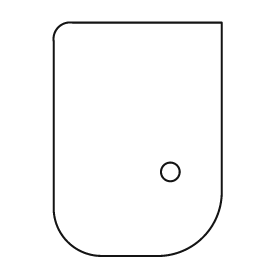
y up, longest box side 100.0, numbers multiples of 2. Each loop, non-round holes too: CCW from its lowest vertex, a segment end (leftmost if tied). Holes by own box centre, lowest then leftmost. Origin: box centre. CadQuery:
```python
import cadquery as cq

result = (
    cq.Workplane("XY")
    .moveTo(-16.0, -50.0)
    .lineTo(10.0, -50.0)
    .threePointArc((28.0, -42.0), (36.0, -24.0))
    .lineTo(36.0, 50.0)
    .lineTo(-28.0, 50.0)
    .threePointArc((-34.0, 48.0), (-36.0, 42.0))
    .lineTo(-36.0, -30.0)
    .threePointArc((-30.0, -44.0), (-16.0, -50.0))
    .close()
    .moveTo(14.0, -14.0)
    .circle(4.0)
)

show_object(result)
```